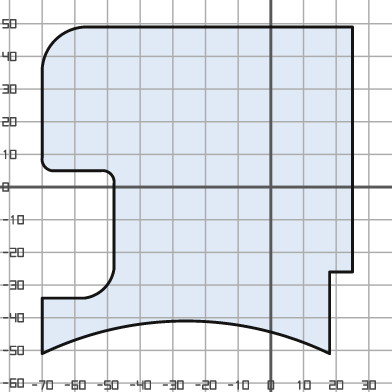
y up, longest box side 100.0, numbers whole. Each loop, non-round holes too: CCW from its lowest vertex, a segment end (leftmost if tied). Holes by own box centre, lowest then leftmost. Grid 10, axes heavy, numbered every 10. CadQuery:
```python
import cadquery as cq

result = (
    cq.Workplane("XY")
    .moveTo(-70.0, -51.0)
    .threePointArc((-26.0, -41.0), (18.0, -51.0))
    .lineTo(18.0, -26.0)
    .lineTo(25.0, -26.0)
    .lineTo(25.0, 49.0)
    .lineTo(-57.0, 49.0)
    .threePointArc((-66.0, 45.0), (-70.0, 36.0))
    .lineTo(-70.0, 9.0)
    .threePointArc((-69.0, 6.0), (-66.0, 5.0))
    .lineTo(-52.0, 5.0)
    .threePointArc((-49.0, 4.0), (-48.0, 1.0))
    .lineTo(-48.0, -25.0)
    .threePointArc((-51.0, -31.0), (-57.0, -34.0))
    .lineTo(-70.0, -34.0)
    .close()
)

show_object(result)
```